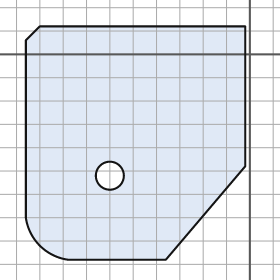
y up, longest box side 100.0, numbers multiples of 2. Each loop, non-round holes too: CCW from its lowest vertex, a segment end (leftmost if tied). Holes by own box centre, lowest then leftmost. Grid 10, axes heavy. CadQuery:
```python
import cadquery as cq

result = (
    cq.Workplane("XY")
    .moveTo(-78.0, -88.0)
    .lineTo(-36.0, -88.0)
    .lineTo(-2.0, -48.0)
    .lineTo(-2.0, 12.0)
    .lineTo(-90.0, 12.0)
    .lineTo(-96.0, 6.0)
    .lineTo(-96.0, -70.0)
    .threePointArc((-90.0, -82.0), (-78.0, -88.0))
    .close()
    .moveTo(-60.0, -52.0)
    .circle(6.0)
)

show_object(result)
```